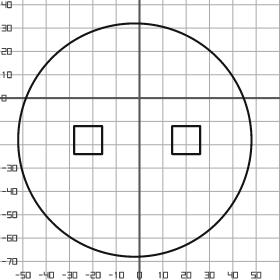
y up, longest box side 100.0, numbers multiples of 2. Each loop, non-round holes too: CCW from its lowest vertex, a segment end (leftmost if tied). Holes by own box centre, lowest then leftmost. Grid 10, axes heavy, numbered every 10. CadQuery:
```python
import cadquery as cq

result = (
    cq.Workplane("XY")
    .moveTo(-2.0, -18.0)
    .circle(50.0)
    .moveTo(-28.0, -24.0)
    .lineTo(-16.0, -24.0)
    .lineTo(-16.0, -12.0)
    .lineTo(-28.0, -12.0)
    .close()
    .moveTo(14.0, -24.0)
    .lineTo(26.0, -24.0)
    .lineTo(26.0, -12.0)
    .lineTo(14.0, -12.0)
    .close()
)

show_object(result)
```